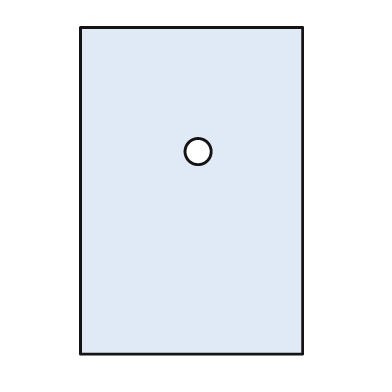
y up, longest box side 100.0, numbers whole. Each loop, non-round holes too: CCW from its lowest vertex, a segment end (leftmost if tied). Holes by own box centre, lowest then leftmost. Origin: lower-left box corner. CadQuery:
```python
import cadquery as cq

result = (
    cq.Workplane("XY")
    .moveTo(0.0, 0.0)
    .lineTo(68.0, 0.0)
    .lineTo(68.0, 100.0)
    .lineTo(0.0, 100.0)
    .close()
    .moveTo(36.0, 62.0)
    .circle(4.0)
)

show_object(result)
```